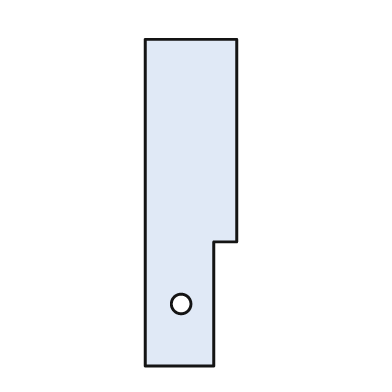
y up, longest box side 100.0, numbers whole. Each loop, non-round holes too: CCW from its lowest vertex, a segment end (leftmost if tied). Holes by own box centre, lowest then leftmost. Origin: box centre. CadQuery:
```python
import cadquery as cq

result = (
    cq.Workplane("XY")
    .moveTo(-14.0, -50.0)
    .lineTo(7.0, -50.0)
    .lineTo(7.0, -12.0)
    .lineTo(14.0, -12.0)
    .lineTo(14.0, 50.0)
    .lineTo(-14.0, 50.0)
    .close()
    .moveTo(-3.0, -31.0)
    .circle(3.0)
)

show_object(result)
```